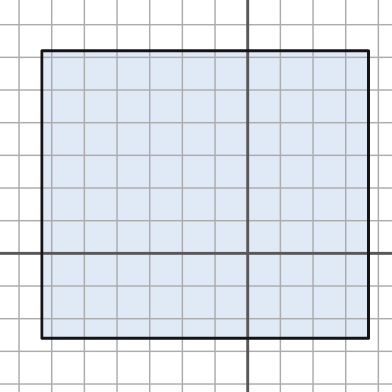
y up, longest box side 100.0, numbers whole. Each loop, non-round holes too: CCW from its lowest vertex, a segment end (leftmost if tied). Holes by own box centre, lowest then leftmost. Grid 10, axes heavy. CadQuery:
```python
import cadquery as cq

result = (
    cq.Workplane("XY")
    .moveTo(-63.0, -26.0)
    .lineTo(37.0, -26.0)
    .lineTo(37.0, 62.0)
    .lineTo(-63.0, 62.0)
    .close()
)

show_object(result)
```